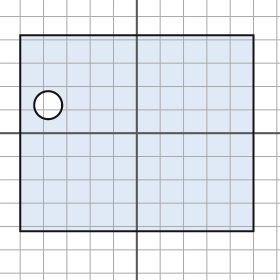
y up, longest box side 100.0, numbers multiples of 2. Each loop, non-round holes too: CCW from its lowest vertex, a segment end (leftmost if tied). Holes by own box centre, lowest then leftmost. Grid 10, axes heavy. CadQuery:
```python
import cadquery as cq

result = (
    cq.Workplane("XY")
    .moveTo(-50.0, -42.0)
    .lineTo(50.0, -42.0)
    .lineTo(50.0, 42.0)
    .lineTo(-50.0, 42.0)
    .close()
    .moveTo(-38.0, 12.0)
    .circle(6.0)
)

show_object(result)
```